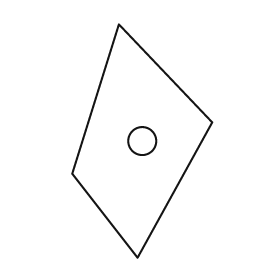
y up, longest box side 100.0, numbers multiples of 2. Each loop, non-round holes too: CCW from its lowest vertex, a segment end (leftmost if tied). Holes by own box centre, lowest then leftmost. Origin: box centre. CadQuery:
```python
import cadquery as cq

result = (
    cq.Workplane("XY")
    .moveTo(-2.0, -50.0)
    .lineTo(30.0, 8.0)
    .lineTo(-10.0, 50.0)
    .lineTo(-30.0, -14.0)
    .close()
    .moveTo(0.0, 0.0)
    .circle(6.0)
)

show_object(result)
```